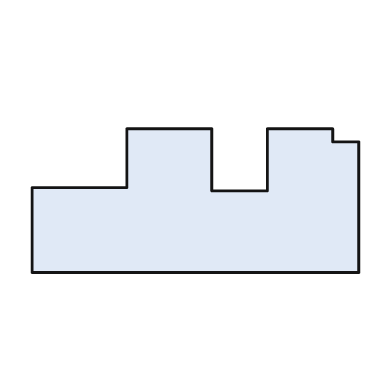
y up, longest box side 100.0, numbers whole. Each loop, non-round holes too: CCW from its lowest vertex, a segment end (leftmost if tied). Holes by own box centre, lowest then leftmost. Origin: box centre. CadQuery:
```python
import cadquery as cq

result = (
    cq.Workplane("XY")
    .moveTo(-50.0, -22.0)
    .lineTo(50.0, -22.0)
    .lineTo(50.0, 18.0)
    .lineTo(42.0, 18.0)
    .lineTo(42.0, 22.0)
    .lineTo(22.0, 22.0)
    .lineTo(22.0, 3.0)
    .lineTo(5.0, 3.0)
    .lineTo(5.0, 22.0)
    .lineTo(-21.0, 22.0)
    .lineTo(-21.0, 4.0)
    .lineTo(-50.0, 4.0)
    .close()
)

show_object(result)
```